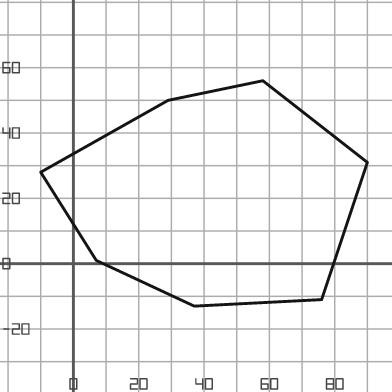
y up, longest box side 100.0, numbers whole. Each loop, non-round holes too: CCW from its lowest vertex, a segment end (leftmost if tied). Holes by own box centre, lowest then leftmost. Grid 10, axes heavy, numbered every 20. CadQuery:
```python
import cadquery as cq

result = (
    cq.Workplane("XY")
    .moveTo(37.0, -13.0)
    .lineTo(76.0, -11.0)
    .lineTo(90.0, 31.0)
    .lineTo(58.0, 56.0)
    .lineTo(29.0, 50.0)
    .lineTo(-10.0, 28.0)
    .lineTo(7.0, 1.0)
    .close()
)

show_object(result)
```